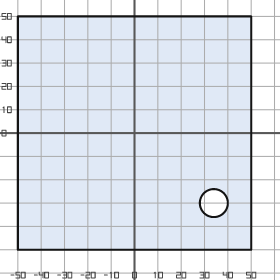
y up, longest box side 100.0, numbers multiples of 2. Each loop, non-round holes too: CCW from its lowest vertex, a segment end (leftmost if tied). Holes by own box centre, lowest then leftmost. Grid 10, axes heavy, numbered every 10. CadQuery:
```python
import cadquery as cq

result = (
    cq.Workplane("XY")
    .moveTo(-50.0, -50.0)
    .lineTo(50.0, -50.0)
    .lineTo(50.0, 50.0)
    .lineTo(-50.0, 50.0)
    .close()
    .moveTo(34.0, -30.0)
    .circle(6.0)
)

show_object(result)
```